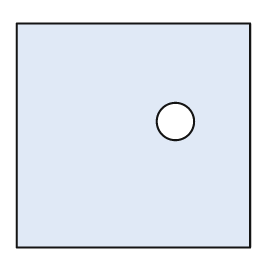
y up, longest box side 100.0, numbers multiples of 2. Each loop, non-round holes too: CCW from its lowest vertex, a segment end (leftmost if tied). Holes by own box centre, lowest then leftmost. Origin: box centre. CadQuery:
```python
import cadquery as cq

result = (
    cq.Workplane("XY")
    .moveTo(-50.0, -48.0)
    .lineTo(50.0, -48.0)
    .lineTo(50.0, 48.0)
    .lineTo(-50.0, 48.0)
    .close()
    .moveTo(18.0, 6.0)
    .circle(8.0)
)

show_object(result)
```